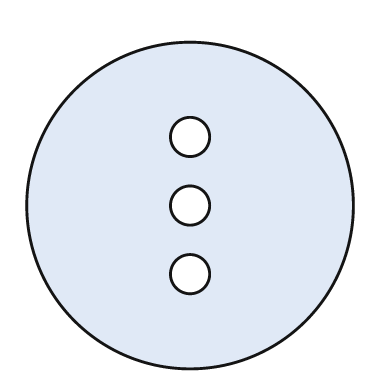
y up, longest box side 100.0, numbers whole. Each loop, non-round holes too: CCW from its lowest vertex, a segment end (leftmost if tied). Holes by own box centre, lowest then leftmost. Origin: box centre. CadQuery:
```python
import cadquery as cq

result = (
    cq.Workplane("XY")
    .moveTo(0.0, 0.0)
    .circle(50.0)
    .moveTo(0.0, -21.0)
    .circle(6.0)
    .moveTo(0.0, 0.0)
    .circle(6.0)
    .moveTo(0.0, 21.0)
    .circle(6.0)
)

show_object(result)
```